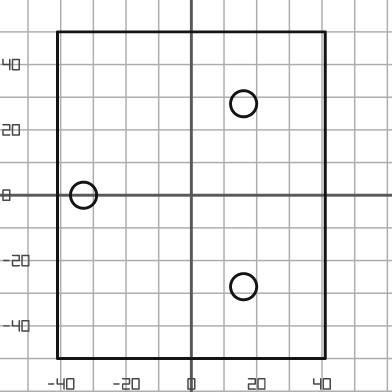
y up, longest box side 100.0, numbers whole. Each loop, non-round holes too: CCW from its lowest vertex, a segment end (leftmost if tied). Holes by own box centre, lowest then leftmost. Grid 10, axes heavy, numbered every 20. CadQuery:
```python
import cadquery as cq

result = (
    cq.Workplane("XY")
    .moveTo(-41.0, -50.0)
    .lineTo(41.0, -50.0)
    .lineTo(41.0, 50.0)
    .lineTo(-41.0, 50.0)
    .close()
    .moveTo(16.0, -28.0)
    .circle(4.0)
    .moveTo(-33.0, 0.0)
    .circle(4.0)
    .moveTo(16.0, 28.0)
    .circle(4.0)
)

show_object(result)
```